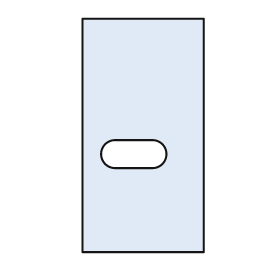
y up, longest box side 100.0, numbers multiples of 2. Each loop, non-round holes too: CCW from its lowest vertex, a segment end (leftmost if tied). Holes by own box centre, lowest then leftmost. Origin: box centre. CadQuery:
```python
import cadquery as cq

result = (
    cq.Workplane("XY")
    .moveTo(-26.0, -50.0)
    .lineTo(26.0, -50.0)
    .lineTo(26.0, 50.0)
    .lineTo(-26.0, 50.0)
    .close()
    .moveTo(-12.0, -14.0)
    .lineTo(4.0, -14.0)
    .threePointArc((10.0, -8.0), (4.0, -2.0))
    .lineTo(-12.0, -2.0)
    .threePointArc((-18.0, -8.0), (-12.0, -14.0))
    .close()
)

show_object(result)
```